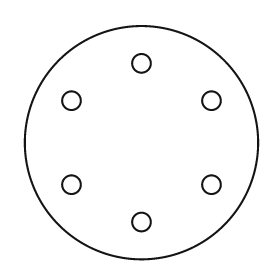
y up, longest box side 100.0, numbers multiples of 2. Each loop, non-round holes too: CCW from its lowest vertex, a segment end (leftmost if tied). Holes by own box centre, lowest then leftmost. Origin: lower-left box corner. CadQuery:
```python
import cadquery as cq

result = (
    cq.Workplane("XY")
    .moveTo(50.0, 50.0)
    .circle(50.0)
    .moveTo(50.0, 16.0)
    .circle(4.0)
    .moveTo(20.0, 32.0)
    .circle(4.0)
    .moveTo(80.0, 32.0)
    .circle(4.0)
    .moveTo(20.0, 68.0)
    .circle(4.0)
    .moveTo(80.0, 68.0)
    .circle(4.0)
    .moveTo(50.0, 84.0)
    .circle(4.0)
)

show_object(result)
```